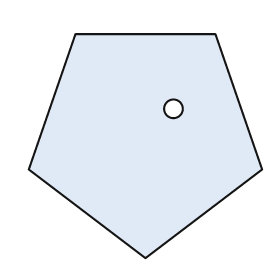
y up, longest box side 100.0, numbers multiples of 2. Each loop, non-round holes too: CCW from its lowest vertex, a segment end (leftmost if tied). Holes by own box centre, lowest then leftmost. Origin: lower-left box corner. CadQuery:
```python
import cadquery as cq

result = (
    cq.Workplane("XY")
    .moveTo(50.0, 0.0)
    .lineTo(100.0, 38.0)
    .lineTo(80.0, 96.0)
    .lineTo(20.0, 96.0)
    .lineTo(0.0, 38.0)
    .close()
    .moveTo(62.0, 64.0)
    .circle(4.0)
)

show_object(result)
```